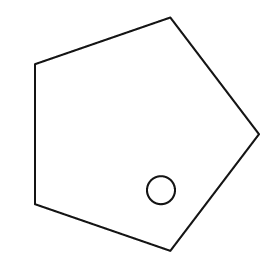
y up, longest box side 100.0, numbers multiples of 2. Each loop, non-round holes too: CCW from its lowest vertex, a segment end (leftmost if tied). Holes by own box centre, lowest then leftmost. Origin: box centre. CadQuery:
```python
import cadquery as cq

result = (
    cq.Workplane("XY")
    .moveTo(10.0, -50.0)
    .lineTo(48.0, 0.0)
    .lineTo(10.0, 50.0)
    .lineTo(-48.0, 30.0)
    .lineTo(-48.0, -30.0)
    .close()
    .moveTo(6.0, -24.0)
    .circle(6.0)
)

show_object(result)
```